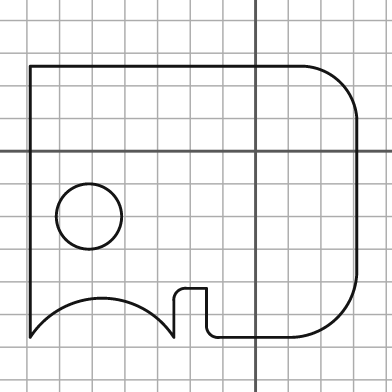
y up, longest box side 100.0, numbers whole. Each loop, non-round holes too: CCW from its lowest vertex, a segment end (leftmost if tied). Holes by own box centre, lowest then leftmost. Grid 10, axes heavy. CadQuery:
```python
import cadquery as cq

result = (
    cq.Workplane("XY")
    .moveTo(-69.0, -57.0)
    .threePointArc((-47.0, -45.0), (-25.0, -57.0))
    .lineTo(-25.0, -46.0)
    .threePointArc((-24.0, -43.0), (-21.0, -42.0))
    .lineTo(-15.0, -42.0)
    .lineTo(-15.0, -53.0)
    .threePointArc((-14.0, -56.0), (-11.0, -57.0))
    .lineTo(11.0, -57.0)
    .threePointArc((25.0, -51.0), (31.0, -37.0))
    .lineTo(31.0, 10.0)
    .threePointArc((26.0, 21.0), (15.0, 26.0))
    .lineTo(-69.0, 26.0)
    .close()
    .moveTo(-51.0, -20.0)
    .circle(10.0)
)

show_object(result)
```